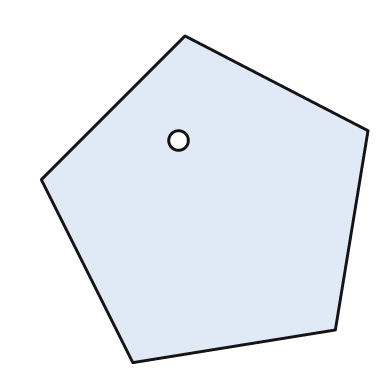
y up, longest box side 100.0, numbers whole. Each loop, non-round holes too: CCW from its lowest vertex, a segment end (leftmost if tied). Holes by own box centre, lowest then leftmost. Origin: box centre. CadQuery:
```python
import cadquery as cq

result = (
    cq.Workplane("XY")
    .moveTo(-22.0, -50.0)
    .lineTo(40.0, -40.0)
    .lineTo(50.0, 21.0)
    .lineTo(-6.0, 50.0)
    .lineTo(-50.0, 6.0)
    .close()
    .moveTo(-8.0, 18.0)
    .circle(3.0)
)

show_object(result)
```